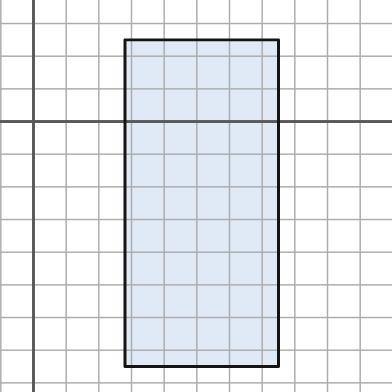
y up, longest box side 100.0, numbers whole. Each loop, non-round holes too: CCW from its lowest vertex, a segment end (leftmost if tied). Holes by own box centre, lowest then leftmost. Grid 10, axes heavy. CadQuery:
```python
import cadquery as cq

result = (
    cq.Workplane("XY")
    .moveTo(28.0, -75.0)
    .lineTo(75.0, -75.0)
    .lineTo(75.0, 25.0)
    .lineTo(28.0, 25.0)
    .close()
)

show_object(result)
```